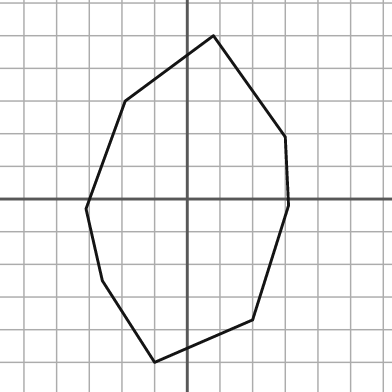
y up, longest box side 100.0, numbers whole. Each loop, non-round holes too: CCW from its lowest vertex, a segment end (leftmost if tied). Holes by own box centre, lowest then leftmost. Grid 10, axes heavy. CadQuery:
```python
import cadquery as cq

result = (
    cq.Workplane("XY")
    .moveTo(-10.0, -50.0)
    .lineTo(20.0, -37.0)
    .lineTo(31.0, -2.0)
    .lineTo(30.0, 19.0)
    .lineTo(8.0, 50.0)
    .lineTo(-19.0, 30.0)
    .lineTo(-31.0, -3.0)
    .lineTo(-26.0, -25.0)
    .close()
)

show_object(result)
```